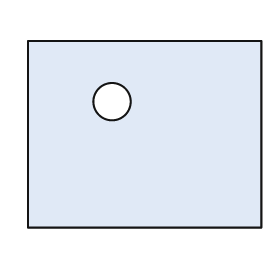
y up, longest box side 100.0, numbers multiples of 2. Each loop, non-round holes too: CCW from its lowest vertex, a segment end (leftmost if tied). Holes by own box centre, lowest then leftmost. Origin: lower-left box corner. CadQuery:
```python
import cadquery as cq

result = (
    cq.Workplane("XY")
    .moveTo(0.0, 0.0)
    .lineTo(100.0, 0.0)
    .lineTo(100.0, 80.0)
    .lineTo(0.0, 80.0)
    .close()
    .moveTo(36.0, 54.0)
    .circle(8.0)
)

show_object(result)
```